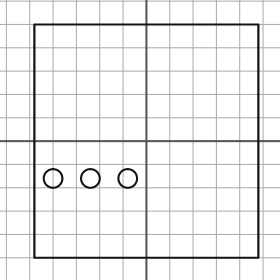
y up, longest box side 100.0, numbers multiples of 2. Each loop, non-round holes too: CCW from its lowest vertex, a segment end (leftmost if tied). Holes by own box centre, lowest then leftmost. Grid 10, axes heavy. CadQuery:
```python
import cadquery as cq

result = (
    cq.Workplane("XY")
    .moveTo(-48.0, -50.0)
    .lineTo(48.0, -50.0)
    .lineTo(48.0, 50.0)
    .lineTo(-48.0, 50.0)
    .close()
    .moveTo(-40.0, -16.0)
    .circle(4.0)
    .moveTo(-24.0, -16.0)
    .circle(4.0)
    .moveTo(-8.0, -16.0)
    .circle(4.0)
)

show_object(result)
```